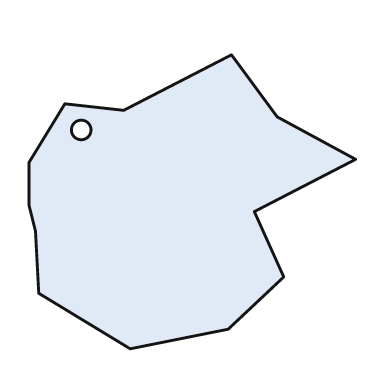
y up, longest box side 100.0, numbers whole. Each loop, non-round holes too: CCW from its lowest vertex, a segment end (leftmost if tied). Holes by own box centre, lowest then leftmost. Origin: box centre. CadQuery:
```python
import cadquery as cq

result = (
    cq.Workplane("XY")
    .moveTo(-19.0, -45.0)
    .lineTo(11.0, -39.0)
    .lineTo(28.0, -23.0)
    .lineTo(19.0, -3.0)
    .lineTo(50.0, 13.0)
    .lineTo(26.0, 26.0)
    .lineTo(12.0, 45.0)
    .lineTo(-21.0, 28.0)
    .lineTo(-39.0, 30.0)
    .lineTo(-50.0, 12.0)
    .lineTo(-50.0, -1.0)
    .lineTo(-48.0, -9.0)
    .lineTo(-47.0, -28.0)
    .close()
    .moveTo(-34.0, 22.0)
    .circle(3.0)
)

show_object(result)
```